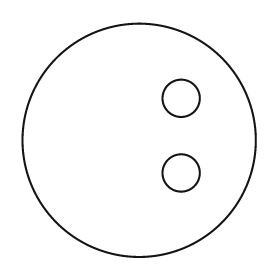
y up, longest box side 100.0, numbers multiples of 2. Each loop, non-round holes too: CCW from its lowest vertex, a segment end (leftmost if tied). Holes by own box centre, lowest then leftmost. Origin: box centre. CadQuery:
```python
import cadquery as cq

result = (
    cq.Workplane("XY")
    .moveTo(0.0, 0.0)
    .circle(50.0)
    .moveTo(18.0, -14.0)
    .circle(8.0)
    .moveTo(18.0, 18.0)
    .circle(8.0)
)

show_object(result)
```